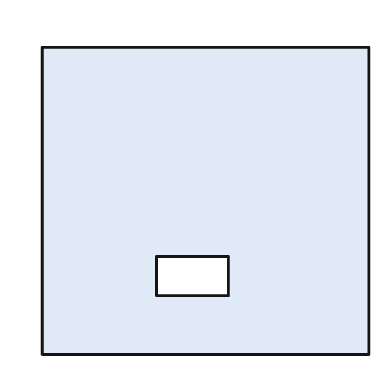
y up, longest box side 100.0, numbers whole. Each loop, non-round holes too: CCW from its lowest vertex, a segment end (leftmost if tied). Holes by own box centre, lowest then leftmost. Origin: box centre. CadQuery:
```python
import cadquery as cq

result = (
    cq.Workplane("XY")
    .moveTo(-50.0, -47.0)
    .lineTo(50.0, -47.0)
    .lineTo(50.0, 47.0)
    .lineTo(-50.0, 47.0)
    .close()
    .moveTo(-15.0, -29.0)
    .lineTo(7.0, -29.0)
    .lineTo(7.0, -17.0)
    .lineTo(-15.0, -17.0)
    .close()
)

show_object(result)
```